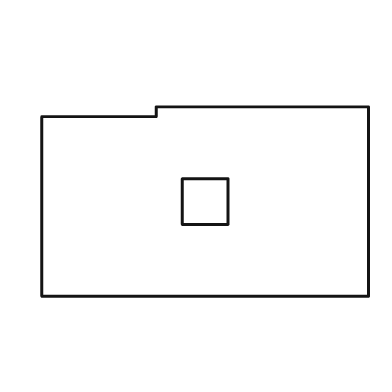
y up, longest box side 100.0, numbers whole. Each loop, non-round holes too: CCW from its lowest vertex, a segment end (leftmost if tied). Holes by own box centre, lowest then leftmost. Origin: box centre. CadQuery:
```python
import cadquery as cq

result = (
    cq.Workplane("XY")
    .moveTo(-50.0, -29.0)
    .lineTo(50.0, -29.0)
    .lineTo(50.0, 29.0)
    .lineTo(-15.0, 29.0)
    .lineTo(-15.0, 26.0)
    .lineTo(-50.0, 26.0)
    .close()
    .moveTo(-7.0, -7.0)
    .lineTo(7.0, -7.0)
    .lineTo(7.0, 7.0)
    .lineTo(-7.0, 7.0)
    .close()
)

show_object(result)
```